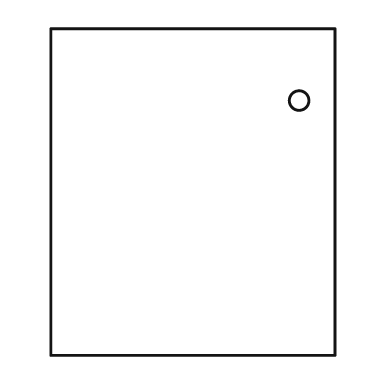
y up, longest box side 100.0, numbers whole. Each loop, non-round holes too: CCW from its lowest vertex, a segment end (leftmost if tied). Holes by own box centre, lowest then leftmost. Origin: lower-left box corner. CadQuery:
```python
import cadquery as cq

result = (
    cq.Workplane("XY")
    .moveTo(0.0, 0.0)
    .lineTo(87.0, 0.0)
    .lineTo(87.0, 100.0)
    .lineTo(0.0, 100.0)
    .close()
    .moveTo(76.0, 78.0)
    .circle(3.0)
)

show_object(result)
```